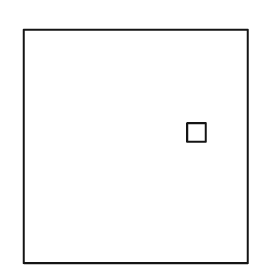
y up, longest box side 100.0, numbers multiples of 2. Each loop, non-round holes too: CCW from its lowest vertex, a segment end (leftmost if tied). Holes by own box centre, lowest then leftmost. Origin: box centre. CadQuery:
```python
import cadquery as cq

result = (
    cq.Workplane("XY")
    .moveTo(-48.0, -50.0)
    .lineTo(48.0, -50.0)
    .lineTo(48.0, 50.0)
    .lineTo(-48.0, 50.0)
    .close()
    .moveTo(22.0, 2.0)
    .lineTo(30.0, 2.0)
    .lineTo(30.0, 10.0)
    .lineTo(22.0, 10.0)
    .close()
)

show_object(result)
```